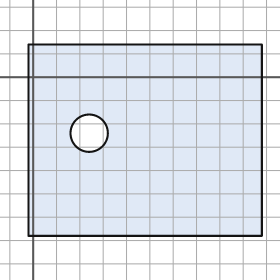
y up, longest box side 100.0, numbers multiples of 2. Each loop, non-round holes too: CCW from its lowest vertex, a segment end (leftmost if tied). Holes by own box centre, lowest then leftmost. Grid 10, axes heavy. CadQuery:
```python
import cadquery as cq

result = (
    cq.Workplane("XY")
    .moveTo(-2.0, -68.0)
    .lineTo(98.0, -68.0)
    .lineTo(98.0, 14.0)
    .lineTo(-2.0, 14.0)
    .close()
    .moveTo(24.0, -24.0)
    .circle(8.0)
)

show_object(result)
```